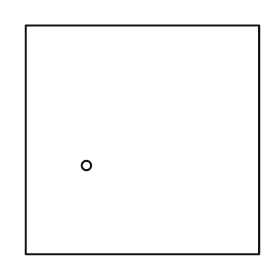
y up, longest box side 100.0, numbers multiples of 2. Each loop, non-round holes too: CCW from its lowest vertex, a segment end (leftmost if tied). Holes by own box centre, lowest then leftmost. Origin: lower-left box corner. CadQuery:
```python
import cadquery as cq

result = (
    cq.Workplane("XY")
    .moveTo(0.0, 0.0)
    .lineTo(100.0, 0.0)
    .lineTo(100.0, 98.0)
    .lineTo(0.0, 98.0)
    .close()
    .moveTo(26.0, 38.0)
    .circle(2.0)
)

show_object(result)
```